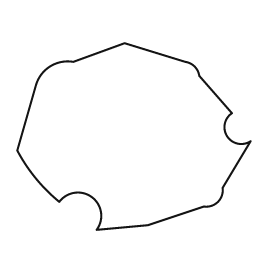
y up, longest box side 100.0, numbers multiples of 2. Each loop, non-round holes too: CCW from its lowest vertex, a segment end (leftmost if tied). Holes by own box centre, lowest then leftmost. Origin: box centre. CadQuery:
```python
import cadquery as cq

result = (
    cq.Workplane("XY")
    .moveTo(-16.0, -40.0)
    .lineTo(6.0, -38.0)
    .lineTo(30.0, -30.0)
    .threePointArc((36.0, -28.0), (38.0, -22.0))
    .lineTo(50.0, -2.0)
    .threePointArc((40.0, 0.0), (42.0, 10.0))
    .lineTo(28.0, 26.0)
    .threePointArc((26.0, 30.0), (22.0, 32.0))
    .lineTo(-4.0, 40.0)
    .lineTo(-26.0, 32.0)
    .threePointArc((-36.0, 30.0), (-42.0, 22.0))
    .lineTo(-50.0, -6.0)
    .threePointArc((-42.0, -18.0), (-32.0, -28.0))
    .threePointArc((-18.0, -26.0), (-16.0, -40.0))
    .close()
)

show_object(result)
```